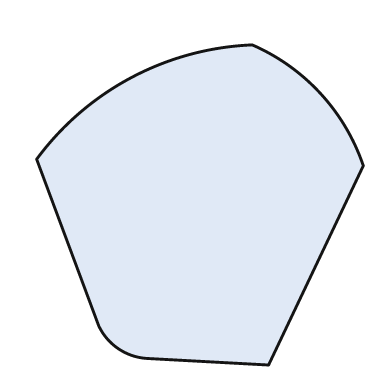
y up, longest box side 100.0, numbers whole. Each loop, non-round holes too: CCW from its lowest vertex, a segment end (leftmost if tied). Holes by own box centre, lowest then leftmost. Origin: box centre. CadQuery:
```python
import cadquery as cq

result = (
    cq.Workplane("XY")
    .moveTo(21.0, -49.0)
    .lineTo(50.0, 12.0)
    .threePointArc((37.0, 34.0), (16.0, 49.0))
    .threePointArc((-21.0, 39.0), (-50.0, 14.0))
    .lineTo(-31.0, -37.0)
    .threePointArc((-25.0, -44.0), (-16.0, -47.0))
    .close()
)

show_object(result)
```